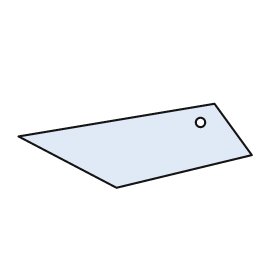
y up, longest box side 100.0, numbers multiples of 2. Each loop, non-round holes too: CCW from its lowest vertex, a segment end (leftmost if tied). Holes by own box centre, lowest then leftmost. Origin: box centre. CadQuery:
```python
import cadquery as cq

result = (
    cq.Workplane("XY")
    .moveTo(-8.0, -18.0)
    .lineTo(50.0, -4.0)
    .lineTo(34.0, 18.0)
    .lineTo(-50.0, 4.0)
    .close()
    .moveTo(28.0, 10.0)
    .circle(2.0)
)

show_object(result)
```